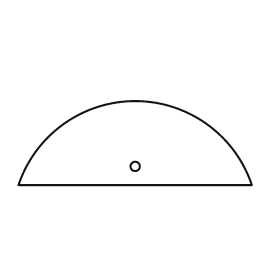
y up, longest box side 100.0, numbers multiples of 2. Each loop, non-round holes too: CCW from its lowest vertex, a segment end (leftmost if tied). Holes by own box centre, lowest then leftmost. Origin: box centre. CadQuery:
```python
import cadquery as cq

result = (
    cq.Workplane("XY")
    .moveTo(-50.0, -18.0)
    .lineTo(50.0, -18.0)
    .threePointArc((0.0, 18.0), (-50.0, -18.0))
    .close()
    .moveTo(0.0, -10.0)
    .circle(2.0)
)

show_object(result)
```